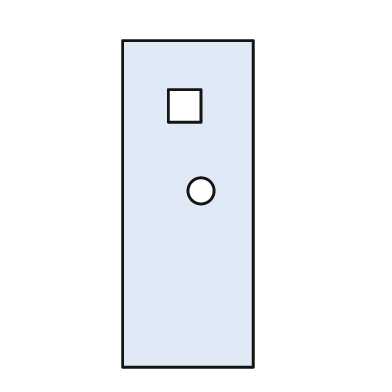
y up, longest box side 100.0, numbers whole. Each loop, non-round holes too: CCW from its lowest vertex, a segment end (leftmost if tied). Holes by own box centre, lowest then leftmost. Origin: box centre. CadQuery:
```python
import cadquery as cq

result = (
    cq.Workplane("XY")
    .moveTo(-20.0, -50.0)
    .lineTo(20.0, -50.0)
    .lineTo(20.0, 50.0)
    .lineTo(-20.0, 50.0)
    .close()
    .moveTo(4.0, 4.0)
    .circle(4.0)
    .moveTo(-6.0, 25.0)
    .lineTo(4.0, 25.0)
    .lineTo(4.0, 35.0)
    .lineTo(-6.0, 35.0)
    .close()
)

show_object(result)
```